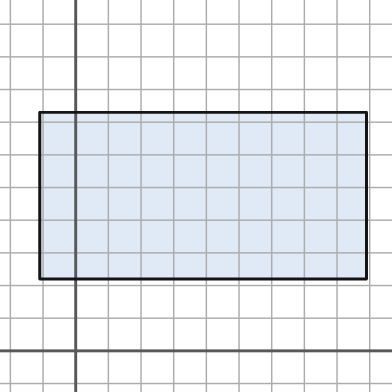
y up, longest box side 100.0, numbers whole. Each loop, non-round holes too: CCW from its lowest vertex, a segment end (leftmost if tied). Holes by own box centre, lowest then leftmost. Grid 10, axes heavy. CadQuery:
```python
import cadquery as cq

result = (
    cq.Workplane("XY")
    .moveTo(-11.0, 22.0)
    .lineTo(89.0, 22.0)
    .lineTo(89.0, 73.0)
    .lineTo(-11.0, 73.0)
    .close()
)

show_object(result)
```